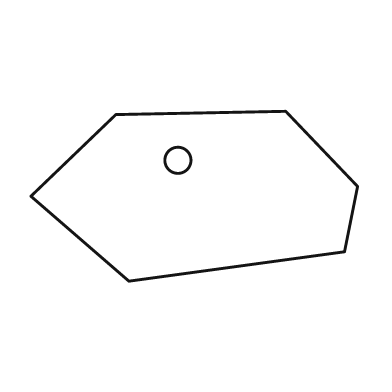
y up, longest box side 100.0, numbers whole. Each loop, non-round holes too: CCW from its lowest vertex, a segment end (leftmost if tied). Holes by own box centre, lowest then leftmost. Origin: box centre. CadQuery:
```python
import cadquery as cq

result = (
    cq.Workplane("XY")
    .moveTo(-20.0, -26.0)
    .lineTo(46.0, -17.0)
    .lineTo(50.0, 3.0)
    .lineTo(28.0, 26.0)
    .lineTo(-24.0, 25.0)
    .lineTo(-50.0, 0.0)
    .close()
    .moveTo(-5.0, 11.0)
    .circle(4.0)
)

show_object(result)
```